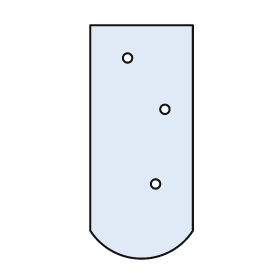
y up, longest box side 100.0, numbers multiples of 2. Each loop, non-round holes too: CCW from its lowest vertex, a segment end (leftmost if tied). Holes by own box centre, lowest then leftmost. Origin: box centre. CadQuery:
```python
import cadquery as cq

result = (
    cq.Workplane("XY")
    .moveTo(-22.0, -38.0)
    .threePointArc((0.0, -50.0), (22.0, -38.0))
    .lineTo(22.0, 50.0)
    .lineTo(-22.0, 50.0)
    .close()
    .moveTo(6.0, -18.0)
    .circle(2.0)
    .moveTo(10.0, 14.0)
    .circle(2.0)
    .moveTo(-6.0, 36.0)
    .circle(2.0)
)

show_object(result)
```